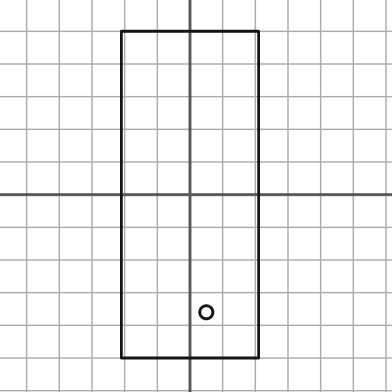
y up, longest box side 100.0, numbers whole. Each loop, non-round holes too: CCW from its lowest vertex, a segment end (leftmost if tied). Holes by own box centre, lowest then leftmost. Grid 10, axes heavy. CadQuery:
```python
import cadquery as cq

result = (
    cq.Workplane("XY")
    .moveTo(-21.0, -50.0)
    .lineTo(21.0, -50.0)
    .lineTo(21.0, 50.0)
    .lineTo(-21.0, 50.0)
    .close()
    .moveTo(5.0, -36.0)
    .circle(2.0)
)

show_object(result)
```